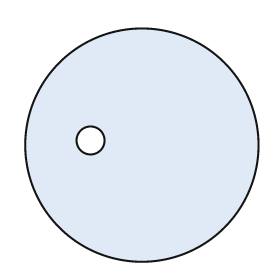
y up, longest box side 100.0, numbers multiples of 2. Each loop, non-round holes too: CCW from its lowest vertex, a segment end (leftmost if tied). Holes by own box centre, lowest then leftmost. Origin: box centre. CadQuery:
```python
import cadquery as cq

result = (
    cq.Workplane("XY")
    .moveTo(0.0, 0.0)
    .circle(50.0)
    .moveTo(-22.0, 2.0)
    .circle(6.0)
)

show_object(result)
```